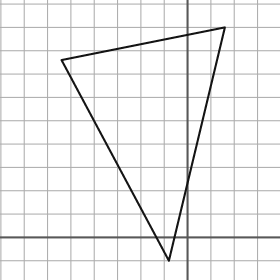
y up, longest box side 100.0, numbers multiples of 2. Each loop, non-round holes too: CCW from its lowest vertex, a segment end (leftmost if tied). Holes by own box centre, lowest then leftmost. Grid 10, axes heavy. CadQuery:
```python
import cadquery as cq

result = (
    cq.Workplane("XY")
    .moveTo(-8.0, -10.0)
    .lineTo(16.0, 90.0)
    .lineTo(-54.0, 76.0)
    .close()
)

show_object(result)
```